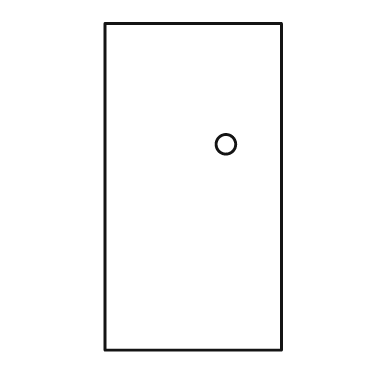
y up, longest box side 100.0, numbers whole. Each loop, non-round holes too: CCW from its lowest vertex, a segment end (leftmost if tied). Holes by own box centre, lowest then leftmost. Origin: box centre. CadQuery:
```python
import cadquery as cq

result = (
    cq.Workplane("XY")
    .moveTo(-27.0, -50.0)
    .lineTo(27.0, -50.0)
    .lineTo(27.0, 50.0)
    .lineTo(-27.0, 50.0)
    .close()
    .moveTo(10.0, 13.0)
    .circle(3.0)
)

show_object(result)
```